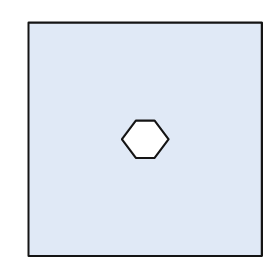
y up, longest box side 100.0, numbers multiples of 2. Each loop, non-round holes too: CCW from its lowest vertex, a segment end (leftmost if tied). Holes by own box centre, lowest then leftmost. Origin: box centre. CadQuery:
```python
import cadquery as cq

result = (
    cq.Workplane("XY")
    .moveTo(-50.0, -50.0)
    .lineTo(50.0, -50.0)
    .lineTo(50.0, 50.0)
    .lineTo(-50.0, 50.0)
    .close()
    .moveTo(-4.0, -8.0)
    .lineTo(4.0, -8.0)
    .lineTo(10.0, 0.0)
    .lineTo(4.0, 8.0)
    .lineTo(-4.0, 8.0)
    .lineTo(-10.0, 0.0)
    .close()
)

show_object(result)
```